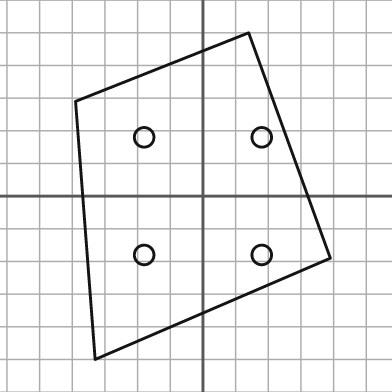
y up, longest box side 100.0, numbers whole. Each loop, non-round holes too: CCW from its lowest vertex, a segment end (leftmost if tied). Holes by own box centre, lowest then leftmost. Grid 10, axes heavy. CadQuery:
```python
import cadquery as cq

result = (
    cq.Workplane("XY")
    .moveTo(-33.0, -50.0)
    .lineTo(39.0, -19.0)
    .lineTo(14.0, 50.0)
    .lineTo(-39.0, 29.0)
    .close()
    .moveTo(-18.0, -18.0)
    .circle(3.0)
    .moveTo(18.0, -18.0)
    .circle(3.0)
    .moveTo(-18.0, 18.0)
    .circle(3.0)
    .moveTo(18.0, 18.0)
    .circle(3.0)
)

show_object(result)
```